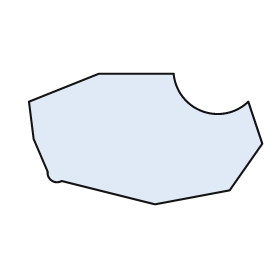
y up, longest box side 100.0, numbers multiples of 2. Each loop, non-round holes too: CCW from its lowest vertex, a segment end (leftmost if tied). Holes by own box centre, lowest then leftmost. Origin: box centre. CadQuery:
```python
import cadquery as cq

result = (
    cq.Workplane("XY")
    .moveTo(4.0, -28.0)
    .lineTo(36.0, -22.0)
    .lineTo(50.0, -2.0)
    .lineTo(44.0, 16.0)
    .threePointArc((24.0, 12.0), (12.0, 28.0))
    .lineTo(-20.0, 28.0)
    .lineTo(-50.0, 16.0)
    .lineTo(-48.0, 0.0)
    .lineTo(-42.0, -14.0)
    .threePointArc((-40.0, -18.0), (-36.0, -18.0))
    .close()
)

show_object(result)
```